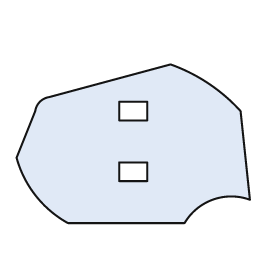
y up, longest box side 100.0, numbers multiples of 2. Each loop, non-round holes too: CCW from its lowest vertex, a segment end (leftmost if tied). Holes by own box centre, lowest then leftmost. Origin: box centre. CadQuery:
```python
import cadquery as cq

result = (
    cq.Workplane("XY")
    .moveTo(-28.0, -34.0)
    .lineTo(22.0, -34.0)
    .threePointArc((34.0, -24.0), (50.0, -24.0))
    .lineTo(46.0, 14.0)
    .threePointArc((32.0, 26.0), (16.0, 34.0))
    .lineTo(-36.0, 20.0)
    .threePointArc((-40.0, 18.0), (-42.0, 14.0))
    .lineTo(-50.0, -6.0)
    .threePointArc((-42.0, -22.0), (-28.0, -34.0))
    .close()
    .moveTo(-6.0, -16.0)
    .lineTo(6.0, -16.0)
    .lineTo(6.0, -8.0)
    .lineTo(-6.0, -8.0)
    .close()
    .moveTo(-6.0, 10.0)
    .lineTo(6.0, 10.0)
    .lineTo(6.0, 18.0)
    .lineTo(-6.0, 18.0)
    .close()
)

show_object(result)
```